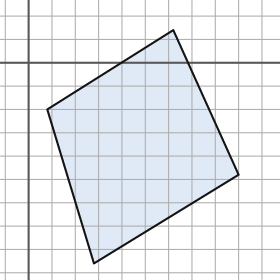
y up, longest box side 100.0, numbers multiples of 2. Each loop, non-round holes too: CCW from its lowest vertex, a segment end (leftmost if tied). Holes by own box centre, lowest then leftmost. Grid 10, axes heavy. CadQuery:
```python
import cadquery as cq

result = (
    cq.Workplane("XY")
    .moveTo(28.0, -86.0)
    .lineTo(90.0, -48.0)
    .lineTo(62.0, 14.0)
    .lineTo(8.0, -20.0)
    .close()
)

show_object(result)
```